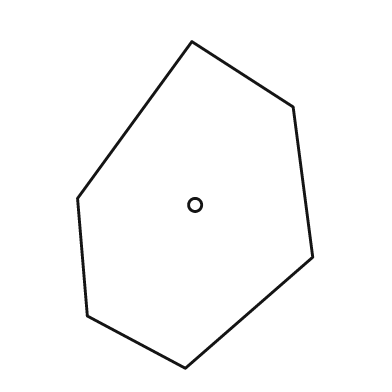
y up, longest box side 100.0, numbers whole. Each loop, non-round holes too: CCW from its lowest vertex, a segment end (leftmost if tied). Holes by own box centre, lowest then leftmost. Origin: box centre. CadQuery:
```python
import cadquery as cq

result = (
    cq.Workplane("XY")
    .moveTo(-3.0, -50.0)
    .lineTo(36.0, -16.0)
    .lineTo(30.0, 30.0)
    .lineTo(-1.0, 50.0)
    .lineTo(-36.0, 2.0)
    .lineTo(-33.0, -34.0)
    .close()
    .moveTo(0.0, 0.0)
    .circle(2.0)
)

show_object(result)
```